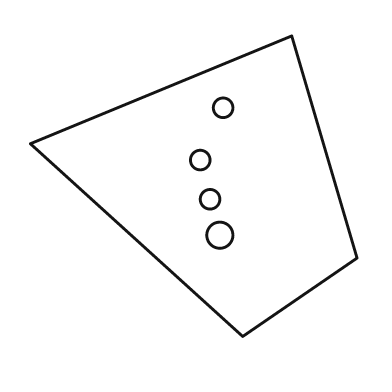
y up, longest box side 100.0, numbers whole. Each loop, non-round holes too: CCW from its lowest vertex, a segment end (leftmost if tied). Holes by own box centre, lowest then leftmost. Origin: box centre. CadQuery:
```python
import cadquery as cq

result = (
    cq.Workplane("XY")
    .moveTo(15.0, -46.0)
    .lineTo(50.0, -22.0)
    .lineTo(30.0, 46.0)
    .lineTo(-50.0, 13.0)
    .close()
    .moveTo(8.0, -15.0)
    .circle(4.0)
    .moveTo(5.0, -4.0)
    .circle(3.0)
    .moveTo(2.0, 8.0)
    .circle(3.0)
    .moveTo(9.0, 24.0)
    .circle(3.0)
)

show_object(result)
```